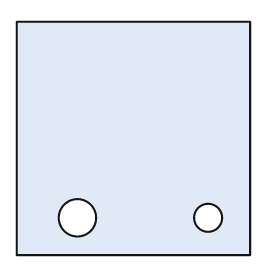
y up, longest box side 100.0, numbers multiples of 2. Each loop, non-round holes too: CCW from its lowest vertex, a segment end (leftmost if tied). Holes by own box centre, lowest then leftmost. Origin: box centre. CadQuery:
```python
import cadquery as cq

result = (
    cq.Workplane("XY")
    .moveTo(-50.0, -50.0)
    .lineTo(50.0, -50.0)
    .lineTo(50.0, 50.0)
    .lineTo(-50.0, 50.0)
    .close()
    .moveTo(-24.0, -34.0)
    .circle(8.0)
    .moveTo(32.0, -34.0)
    .circle(6.0)
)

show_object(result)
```